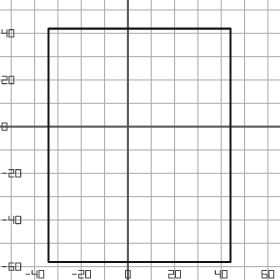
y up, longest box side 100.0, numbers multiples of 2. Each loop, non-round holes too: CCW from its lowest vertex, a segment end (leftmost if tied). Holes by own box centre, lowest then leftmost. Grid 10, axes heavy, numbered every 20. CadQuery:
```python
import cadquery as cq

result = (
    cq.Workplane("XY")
    .moveTo(-34.0, -58.0)
    .lineTo(44.0, -58.0)
    .lineTo(44.0, 42.0)
    .lineTo(-34.0, 42.0)
    .close()
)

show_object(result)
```